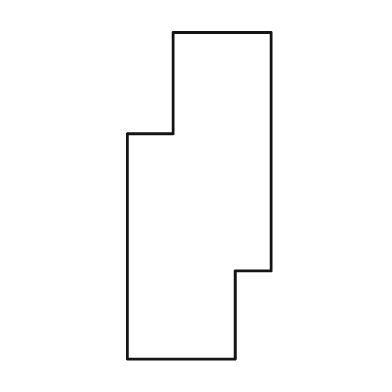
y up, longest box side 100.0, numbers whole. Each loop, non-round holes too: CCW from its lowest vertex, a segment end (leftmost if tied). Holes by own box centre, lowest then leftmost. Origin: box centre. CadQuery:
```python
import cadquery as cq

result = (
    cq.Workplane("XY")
    .moveTo(-22.0, -50.0)
    .lineTo(11.0, -50.0)
    .lineTo(11.0, -23.0)
    .lineTo(22.0, -23.0)
    .lineTo(22.0, 50.0)
    .lineTo(-8.0, 50.0)
    .lineTo(-8.0, 19.0)
    .lineTo(-22.0, 19.0)
    .close()
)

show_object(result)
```